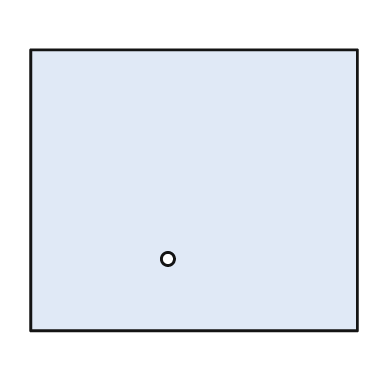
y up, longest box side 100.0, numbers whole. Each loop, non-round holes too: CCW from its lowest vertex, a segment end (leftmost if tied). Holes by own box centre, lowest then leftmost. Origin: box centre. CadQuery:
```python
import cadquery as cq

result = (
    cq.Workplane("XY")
    .moveTo(-50.0, -43.0)
    .lineTo(50.0, -43.0)
    .lineTo(50.0, 43.0)
    .lineTo(-50.0, 43.0)
    .close()
    .moveTo(-8.0, -21.0)
    .circle(2.0)
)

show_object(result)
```